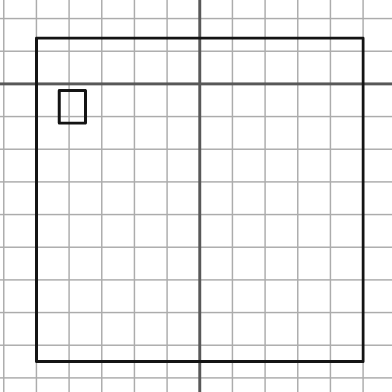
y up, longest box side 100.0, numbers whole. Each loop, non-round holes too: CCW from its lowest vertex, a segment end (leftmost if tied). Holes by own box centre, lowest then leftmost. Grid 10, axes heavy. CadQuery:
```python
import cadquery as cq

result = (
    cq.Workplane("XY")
    .moveTo(-50.0, -85.0)
    .lineTo(50.0, -85.0)
    .lineTo(50.0, 14.0)
    .lineTo(-50.0, 14.0)
    .close()
    .moveTo(-43.0, -12.0)
    .lineTo(-35.0, -12.0)
    .lineTo(-35.0, -2.0)
    .lineTo(-43.0, -2.0)
    .close()
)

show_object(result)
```